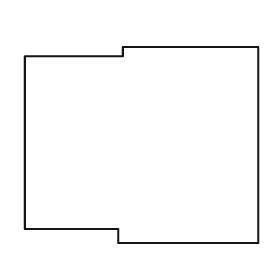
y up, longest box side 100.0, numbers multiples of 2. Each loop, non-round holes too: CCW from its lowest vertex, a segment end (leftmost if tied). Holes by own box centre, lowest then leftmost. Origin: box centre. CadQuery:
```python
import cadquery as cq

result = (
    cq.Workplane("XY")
    .moveTo(-10.0, -42.0)
    .lineTo(50.0, -42.0)
    .lineTo(50.0, 42.0)
    .lineTo(-8.0, 42.0)
    .lineTo(-8.0, 38.0)
    .lineTo(-50.0, 38.0)
    .lineTo(-50.0, -36.0)
    .lineTo(-10.0, -36.0)
    .close()
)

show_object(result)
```